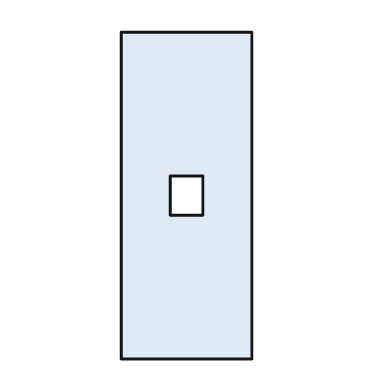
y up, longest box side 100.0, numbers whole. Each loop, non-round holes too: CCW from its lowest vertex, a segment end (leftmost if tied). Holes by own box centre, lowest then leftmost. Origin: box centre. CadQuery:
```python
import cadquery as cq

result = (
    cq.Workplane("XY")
    .moveTo(-20.0, -50.0)
    .lineTo(20.0, -50.0)
    .lineTo(20.0, 50.0)
    .lineTo(-20.0, 50.0)
    .close()
    .moveTo(-5.0, -6.0)
    .lineTo(5.0, -6.0)
    .lineTo(5.0, 6.0)
    .lineTo(-5.0, 6.0)
    .close()
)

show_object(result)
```